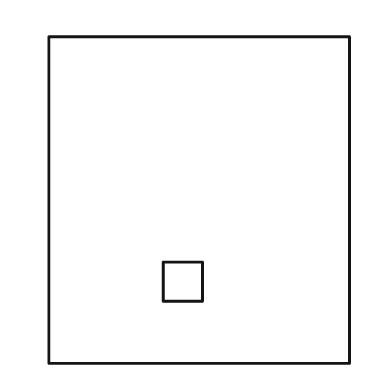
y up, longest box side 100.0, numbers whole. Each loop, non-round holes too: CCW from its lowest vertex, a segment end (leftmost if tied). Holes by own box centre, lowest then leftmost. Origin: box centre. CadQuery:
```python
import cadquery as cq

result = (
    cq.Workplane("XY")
    .moveTo(-46.0, -50.0)
    .lineTo(46.0, -50.0)
    .lineTo(46.0, 50.0)
    .lineTo(-46.0, 50.0)
    .close()
    .moveTo(-11.0, -31.0)
    .lineTo(1.0, -31.0)
    .lineTo(1.0, -19.0)
    .lineTo(-11.0, -19.0)
    .close()
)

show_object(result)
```